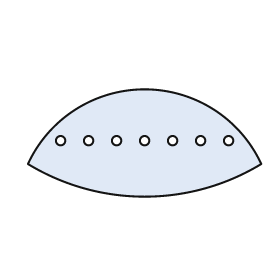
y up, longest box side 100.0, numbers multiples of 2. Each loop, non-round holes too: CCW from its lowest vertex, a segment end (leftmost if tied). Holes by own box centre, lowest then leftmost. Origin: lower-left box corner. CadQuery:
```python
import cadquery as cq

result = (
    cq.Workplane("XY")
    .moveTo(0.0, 14.0)
    .threePointArc((50.0, 0.0), (100.0, 14.0))
    .threePointArc((50.0, 46.0), (0.0, 14.0))
    .close()
    .moveTo(14.0, 24.0)
    .circle(2.0)
    .moveTo(26.0, 24.0)
    .circle(2.0)
    .moveTo(38.0, 24.0)
    .circle(2.0)
    .moveTo(50.0, 24.0)
    .circle(2.0)
    .moveTo(62.0, 24.0)
    .circle(2.0)
    .moveTo(74.0, 24.0)
    .circle(2.0)
    .moveTo(86.0, 24.0)
    .circle(2.0)
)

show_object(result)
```